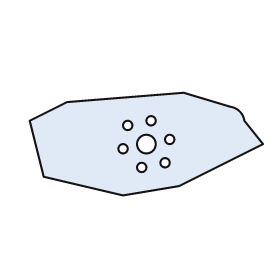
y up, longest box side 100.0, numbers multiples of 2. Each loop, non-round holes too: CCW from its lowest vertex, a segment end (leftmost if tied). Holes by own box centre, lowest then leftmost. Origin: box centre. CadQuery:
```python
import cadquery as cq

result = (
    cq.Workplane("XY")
    .moveTo(-10.0, -22.0)
    .lineTo(14.0, -18.0)
    .lineTo(50.0, 0.0)
    .lineTo(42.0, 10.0)
    .threePointArc((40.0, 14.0), (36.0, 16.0))
    .lineTo(16.0, 22.0)
    .lineTo(-34.0, 18.0)
    .lineTo(-50.0, 10.0)
    .lineTo(-44.0, -14.0)
    .close()
    .moveTo(-2.0, -10.0)
    .circle(2.0)
    .moveTo(8.0, -8.0)
    .circle(2.0)
    .moveTo(-10.0, -2.0)
    .circle(2.0)
    .moveTo(0.0, 0.0)
    .circle(4.0)
    .moveTo(10.0, 2.0)
    .circle(2.0)
    .moveTo(-8.0, 8.0)
    .circle(2.0)
    .moveTo(2.0, 10.0)
    .circle(2.0)
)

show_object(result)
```